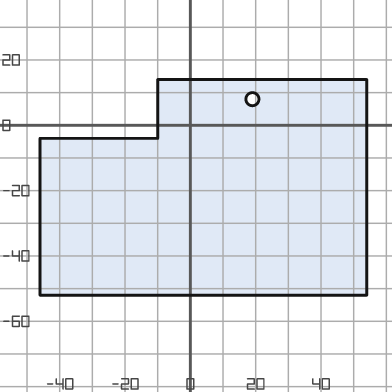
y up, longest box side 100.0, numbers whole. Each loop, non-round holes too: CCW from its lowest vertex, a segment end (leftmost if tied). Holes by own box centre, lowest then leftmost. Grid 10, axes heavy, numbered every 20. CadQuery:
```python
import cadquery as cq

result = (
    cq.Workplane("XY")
    .moveTo(-46.0, -52.0)
    .lineTo(54.0, -52.0)
    .lineTo(54.0, 14.0)
    .lineTo(-10.0, 14.0)
    .lineTo(-10.0, -4.0)
    .lineTo(-46.0, -4.0)
    .close()
    .moveTo(19.0, 8.0)
    .circle(2.0)
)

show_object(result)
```